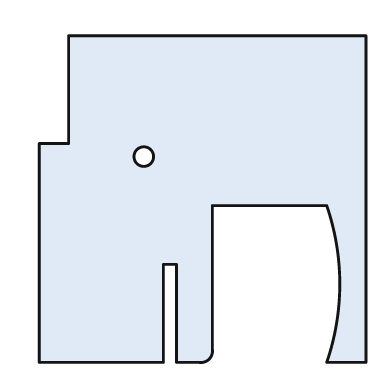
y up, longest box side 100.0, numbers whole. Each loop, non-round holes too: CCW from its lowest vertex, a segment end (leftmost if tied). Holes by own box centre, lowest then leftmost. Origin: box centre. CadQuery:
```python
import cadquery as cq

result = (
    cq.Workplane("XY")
    .moveTo(-50.0, -50.0)
    .lineTo(-12.0, -50.0)
    .lineTo(-12.0, -20.0)
    .lineTo(-8.0, -20.0)
    .lineTo(-8.0, -50.0)
    .lineTo(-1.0, -50.0)
    .threePointArc((2.0, -49.0), (3.0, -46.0))
    .lineTo(3.0, -2.0)
    .lineTo(38.0, -2.0)
    .threePointArc((42.0, -26.0), (38.0, -50.0))
    .lineTo(50.0, -50.0)
    .lineTo(50.0, 50.0)
    .lineTo(-41.0, 50.0)
    .lineTo(-41.0, 17.0)
    .lineTo(-50.0, 17.0)
    .close()
    .moveTo(-18.0, 13.0)
    .circle(3.0)
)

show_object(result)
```